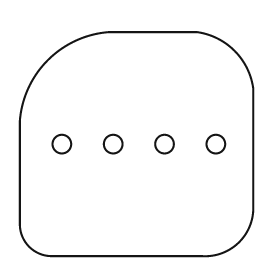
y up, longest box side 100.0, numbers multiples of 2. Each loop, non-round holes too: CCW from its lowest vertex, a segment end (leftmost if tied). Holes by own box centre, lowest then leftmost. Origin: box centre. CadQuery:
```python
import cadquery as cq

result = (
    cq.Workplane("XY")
    .moveTo(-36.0, -48.0)
    .lineTo(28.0, -48.0)
    .threePointArc((44.0, -42.0), (50.0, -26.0))
    .lineTo(50.0, 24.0)
    .threePointArc((42.0, 40.0), (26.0, 48.0))
    .lineTo(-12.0, 48.0)
    .threePointArc((-38.0, 36.0), (-50.0, 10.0))
    .lineTo(-50.0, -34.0)
    .threePointArc((-46.0, -44.0), (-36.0, -48.0))
    .close()
    .moveTo(-32.0, 0.0)
    .circle(4.0)
    .moveTo(-10.0, 0.0)
    .circle(4.0)
    .moveTo(12.0, 0.0)
    .circle(4.0)
    .moveTo(34.0, 0.0)
    .circle(4.0)
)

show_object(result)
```